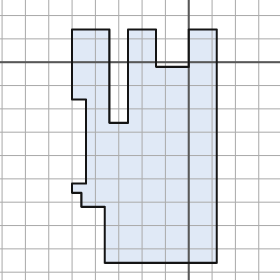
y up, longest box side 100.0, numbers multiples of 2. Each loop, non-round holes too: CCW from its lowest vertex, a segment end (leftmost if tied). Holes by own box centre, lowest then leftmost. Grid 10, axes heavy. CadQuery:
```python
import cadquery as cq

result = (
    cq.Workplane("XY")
    .moveTo(-36.0, -86.0)
    .lineTo(12.0, -86.0)
    .lineTo(12.0, 14.0)
    .lineTo(0.0, 14.0)
    .lineTo(0.0, -2.0)
    .lineTo(-14.0, -2.0)
    .lineTo(-14.0, 14.0)
    .lineTo(-26.0, 14.0)
    .lineTo(-26.0, -26.0)
    .lineTo(-34.0, -26.0)
    .lineTo(-34.0, 14.0)
    .lineTo(-50.0, 14.0)
    .lineTo(-50.0, -16.0)
    .lineTo(-44.0, -16.0)
    .lineTo(-44.0, -52.0)
    .lineTo(-50.0, -52.0)
    .lineTo(-50.0, -56.0)
    .lineTo(-46.0, -56.0)
    .lineTo(-46.0, -62.0)
    .lineTo(-36.0, -62.0)
    .close()
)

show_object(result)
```